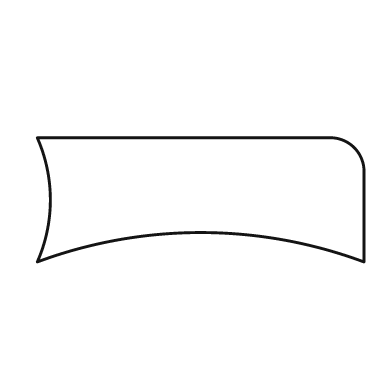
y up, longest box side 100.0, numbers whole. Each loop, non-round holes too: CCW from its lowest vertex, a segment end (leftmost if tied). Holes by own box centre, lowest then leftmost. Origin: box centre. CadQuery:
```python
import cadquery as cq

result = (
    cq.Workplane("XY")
    .moveTo(-50.0, -19.0)
    .threePointArc((0.0, -10.0), (50.0, -19.0))
    .lineTo(50.0, 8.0)
    .threePointArc((47.0, 16.0), (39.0, 19.0))
    .lineTo(-50.0, 19.0)
    .threePointArc((-46.0, 0.0), (-50.0, -19.0))
    .close()
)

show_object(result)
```